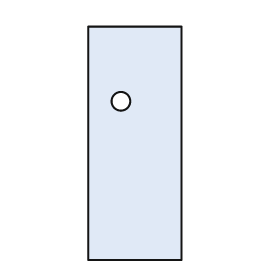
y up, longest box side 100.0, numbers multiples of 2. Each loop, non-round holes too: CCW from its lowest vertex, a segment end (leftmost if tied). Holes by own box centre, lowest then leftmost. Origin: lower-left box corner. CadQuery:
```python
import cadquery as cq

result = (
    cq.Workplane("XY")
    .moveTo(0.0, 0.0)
    .lineTo(40.0, 0.0)
    .lineTo(40.0, 100.0)
    .lineTo(0.0, 100.0)
    .close()
    .moveTo(14.0, 68.0)
    .circle(4.0)
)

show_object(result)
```